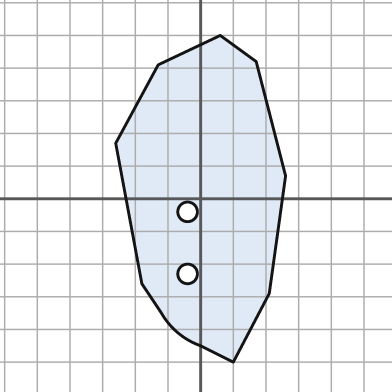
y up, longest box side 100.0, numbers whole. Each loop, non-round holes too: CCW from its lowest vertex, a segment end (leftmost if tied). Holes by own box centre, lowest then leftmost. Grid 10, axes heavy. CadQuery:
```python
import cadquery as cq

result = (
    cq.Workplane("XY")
    .moveTo(10.0, -50.0)
    .lineTo(21.0, -29.0)
    .lineTo(26.0, 7.0)
    .lineTo(17.0, 42.0)
    .lineTo(6.0, 50.0)
    .lineTo(-13.0, 41.0)
    .lineTo(-26.0, 17.0)
    .lineTo(-18.0, -26.0)
    .lineTo(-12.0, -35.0)
    .threePointArc((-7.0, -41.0), (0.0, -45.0))
    .close()
    .moveTo(-4.0, -23.0)
    .circle(3.0)
    .moveTo(-4.0, -4.0)
    .circle(3.0)
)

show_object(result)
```